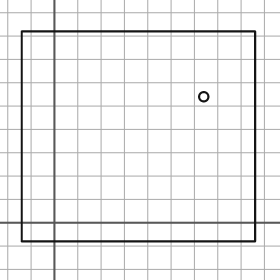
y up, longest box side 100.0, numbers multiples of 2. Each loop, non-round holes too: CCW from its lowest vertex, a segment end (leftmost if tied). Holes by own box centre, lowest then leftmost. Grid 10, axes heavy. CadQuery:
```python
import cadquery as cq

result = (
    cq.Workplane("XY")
    .moveTo(-14.0, -8.0)
    .lineTo(86.0, -8.0)
    .lineTo(86.0, 82.0)
    .lineTo(-14.0, 82.0)
    .close()
    .moveTo(64.0, 54.0)
    .circle(2.0)
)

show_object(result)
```